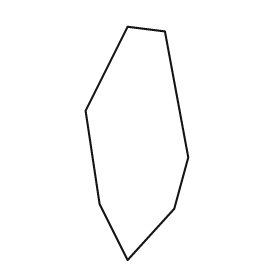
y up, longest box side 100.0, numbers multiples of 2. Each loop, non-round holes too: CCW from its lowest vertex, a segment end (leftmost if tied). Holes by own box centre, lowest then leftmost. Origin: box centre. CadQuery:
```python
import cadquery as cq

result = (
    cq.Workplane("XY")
    .moveTo(-4.0, -50.0)
    .lineTo(16.0, -28.0)
    .lineTo(22.0, -6.0)
    .lineTo(12.0, 48.0)
    .lineTo(-4.0, 50.0)
    .lineTo(-22.0, 14.0)
    .lineTo(-16.0, -26.0)
    .close()
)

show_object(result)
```